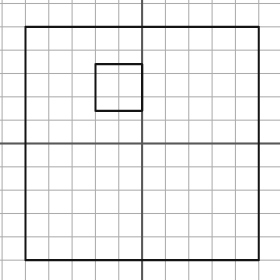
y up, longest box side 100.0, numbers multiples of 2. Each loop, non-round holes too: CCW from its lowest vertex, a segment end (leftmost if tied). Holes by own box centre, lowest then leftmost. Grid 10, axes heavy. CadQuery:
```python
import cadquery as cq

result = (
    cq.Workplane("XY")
    .moveTo(-50.0, -50.0)
    .lineTo(50.0, -50.0)
    .lineTo(50.0, 50.0)
    .lineTo(-50.0, 50.0)
    .close()
    .moveTo(-20.0, 14.0)
    .lineTo(0.0, 14.0)
    .lineTo(0.0, 34.0)
    .lineTo(-20.0, 34.0)
    .close()
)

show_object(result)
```